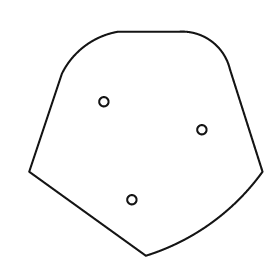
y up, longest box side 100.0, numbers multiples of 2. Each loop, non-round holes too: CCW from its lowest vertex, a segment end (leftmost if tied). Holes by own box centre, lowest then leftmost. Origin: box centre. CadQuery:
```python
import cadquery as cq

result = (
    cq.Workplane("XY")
    .moveTo(0.0, -48.0)
    .threePointArc((28.0, -34.0), (50.0, -12.0))
    .lineTo(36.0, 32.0)
    .threePointArc((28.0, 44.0), (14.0, 48.0))
    .lineTo(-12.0, 48.0)
    .threePointArc((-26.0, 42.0), (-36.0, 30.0))
    .lineTo(-50.0, -12.0)
    .close()
    .moveTo(-6.0, -24.0)
    .circle(2.0)
    .moveTo(24.0, 6.0)
    .circle(2.0)
    .moveTo(-18.0, 18.0)
    .circle(2.0)
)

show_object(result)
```